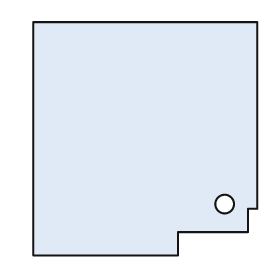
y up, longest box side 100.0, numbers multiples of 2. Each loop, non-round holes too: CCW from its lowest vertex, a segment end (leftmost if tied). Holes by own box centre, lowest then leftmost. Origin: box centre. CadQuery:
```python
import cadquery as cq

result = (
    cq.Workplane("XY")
    .moveTo(-48.0, -50.0)
    .lineTo(14.0, -50.0)
    .lineTo(14.0, -40.0)
    .lineTo(44.0, -40.0)
    .lineTo(44.0, -30.0)
    .lineTo(48.0, -30.0)
    .lineTo(48.0, 50.0)
    .lineTo(-48.0, 50.0)
    .close()
    .moveTo(34.0, -28.0)
    .circle(4.0)
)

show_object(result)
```